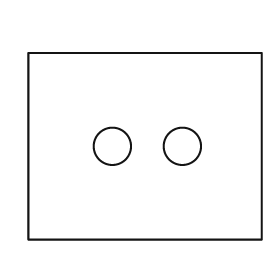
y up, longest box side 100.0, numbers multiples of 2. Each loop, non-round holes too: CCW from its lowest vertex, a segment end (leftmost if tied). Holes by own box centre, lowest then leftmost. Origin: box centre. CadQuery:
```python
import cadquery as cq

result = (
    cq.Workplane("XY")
    .moveTo(-50.0, -40.0)
    .lineTo(50.0, -40.0)
    .lineTo(50.0, 40.0)
    .lineTo(-50.0, 40.0)
    .close()
    .moveTo(-14.0, 0.0)
    .circle(8.0)
    .moveTo(16.0, 0.0)
    .circle(8.0)
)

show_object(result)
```